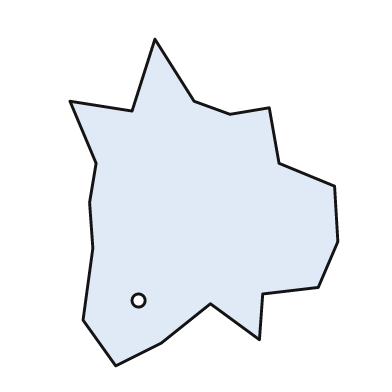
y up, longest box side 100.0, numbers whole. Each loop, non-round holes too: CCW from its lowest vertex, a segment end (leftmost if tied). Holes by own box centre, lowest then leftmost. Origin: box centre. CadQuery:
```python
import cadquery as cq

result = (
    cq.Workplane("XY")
    .moveTo(-27.0, -50.0)
    .lineTo(-13.0, -43.0)
    .lineTo(2.0, -31.0)
    .lineTo(17.0, -42.0)
    .lineTo(18.0, -28.0)
    .lineTo(35.0, -26.0)
    .lineTo(41.0, -12.0)
    .lineTo(40.0, 5.0)
    .lineTo(23.0, 12.0)
    .lineTo(20.0, 29.0)
    .lineTo(8.0, 27.0)
    .lineTo(-3.0, 31.0)
    .lineTo(-15.0, 50.0)
    .lineTo(-22.0, 28.0)
    .lineTo(-41.0, 31.0)
    .lineTo(-33.0, 12.0)
    .lineTo(-35.0, 0.0)
    .lineTo(-34.0, -14.0)
    .lineTo(-37.0, -36.0)
    .close()
    .moveTo(-20.0, -30.0)
    .circle(2.0)
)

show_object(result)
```